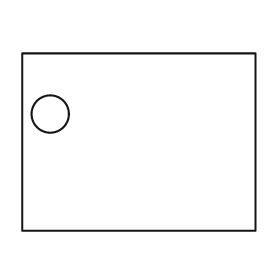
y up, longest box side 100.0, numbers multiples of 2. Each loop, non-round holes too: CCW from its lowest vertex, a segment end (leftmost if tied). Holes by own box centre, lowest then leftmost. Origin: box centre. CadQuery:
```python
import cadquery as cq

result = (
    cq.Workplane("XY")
    .moveTo(-50.0, -38.0)
    .lineTo(50.0, -38.0)
    .lineTo(50.0, 38.0)
    .lineTo(-50.0, 38.0)
    .close()
    .moveTo(-38.0, 12.0)
    .circle(8.0)
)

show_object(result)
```